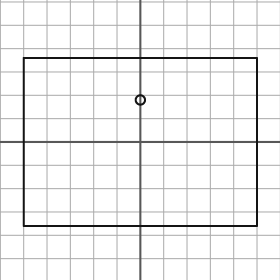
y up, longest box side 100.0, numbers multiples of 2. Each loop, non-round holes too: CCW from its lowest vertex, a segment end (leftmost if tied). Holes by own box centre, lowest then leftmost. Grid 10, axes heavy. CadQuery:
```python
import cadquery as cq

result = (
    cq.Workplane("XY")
    .moveTo(-50.0, -36.0)
    .lineTo(50.0, -36.0)
    .lineTo(50.0, 36.0)
    .lineTo(-50.0, 36.0)
    .close()
    .moveTo(0.0, 18.0)
    .circle(2.0)
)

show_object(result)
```